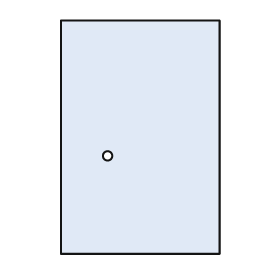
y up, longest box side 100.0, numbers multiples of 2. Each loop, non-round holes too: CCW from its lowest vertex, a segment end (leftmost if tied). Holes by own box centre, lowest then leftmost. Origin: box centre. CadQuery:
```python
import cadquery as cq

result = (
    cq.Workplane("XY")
    .moveTo(-34.0, -50.0)
    .lineTo(34.0, -50.0)
    .lineTo(34.0, 50.0)
    .lineTo(-34.0, 50.0)
    .close()
    .moveTo(-14.0, -8.0)
    .circle(2.0)
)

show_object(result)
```